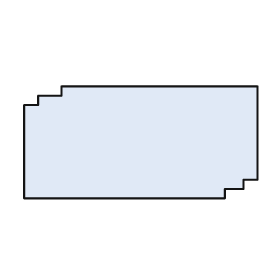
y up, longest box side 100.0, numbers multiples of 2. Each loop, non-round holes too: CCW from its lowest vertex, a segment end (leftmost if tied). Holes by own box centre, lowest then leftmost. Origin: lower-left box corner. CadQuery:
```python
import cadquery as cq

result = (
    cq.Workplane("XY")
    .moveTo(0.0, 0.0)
    .lineTo(86.0, 0.0)
    .lineTo(86.0, 4.0)
    .lineTo(94.0, 4.0)
    .lineTo(94.0, 8.0)
    .lineTo(100.0, 8.0)
    .lineTo(100.0, 48.0)
    .lineTo(16.0, 48.0)
    .lineTo(16.0, 44.0)
    .lineTo(6.0, 44.0)
    .lineTo(6.0, 40.0)
    .lineTo(0.0, 40.0)
    .close()
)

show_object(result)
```